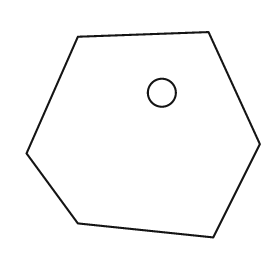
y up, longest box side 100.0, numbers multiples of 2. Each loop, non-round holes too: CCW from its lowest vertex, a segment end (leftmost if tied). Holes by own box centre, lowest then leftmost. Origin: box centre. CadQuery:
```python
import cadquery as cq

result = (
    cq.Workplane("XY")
    .moveTo(30.0, -44.0)
    .lineTo(50.0, -4.0)
    .lineTo(28.0, 44.0)
    .lineTo(-28.0, 42.0)
    .lineTo(-50.0, -8.0)
    .lineTo(-28.0, -38.0)
    .close()
    .moveTo(8.0, 18.0)
    .circle(6.0)
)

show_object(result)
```